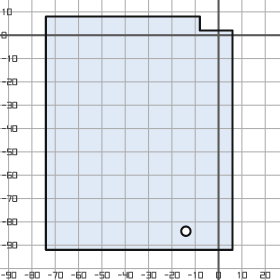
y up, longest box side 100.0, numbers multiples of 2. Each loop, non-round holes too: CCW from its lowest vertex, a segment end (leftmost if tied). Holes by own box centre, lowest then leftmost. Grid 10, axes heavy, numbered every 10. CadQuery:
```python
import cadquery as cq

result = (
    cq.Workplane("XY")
    .moveTo(-74.0, -92.0)
    .lineTo(6.0, -92.0)
    .lineTo(6.0, 2.0)
    .lineTo(-8.0, 2.0)
    .lineTo(-8.0, 8.0)
    .lineTo(-74.0, 8.0)
    .close()
    .moveTo(-14.0, -84.0)
    .circle(2.0)
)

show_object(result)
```